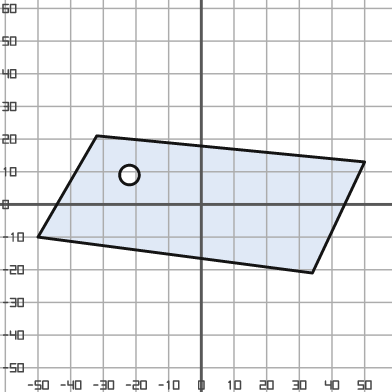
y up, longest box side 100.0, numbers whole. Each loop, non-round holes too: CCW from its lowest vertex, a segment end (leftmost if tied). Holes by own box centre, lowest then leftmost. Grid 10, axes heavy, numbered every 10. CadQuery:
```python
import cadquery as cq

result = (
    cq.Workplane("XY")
    .moveTo(34.0, -21.0)
    .lineTo(50.0, 13.0)
    .lineTo(-32.0, 21.0)
    .lineTo(-50.0, -10.0)
    .close()
    .moveTo(-22.0, 9.0)
    .circle(3.0)
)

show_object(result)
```